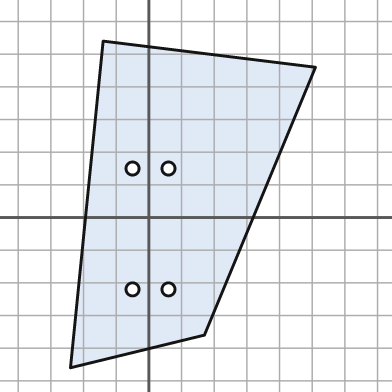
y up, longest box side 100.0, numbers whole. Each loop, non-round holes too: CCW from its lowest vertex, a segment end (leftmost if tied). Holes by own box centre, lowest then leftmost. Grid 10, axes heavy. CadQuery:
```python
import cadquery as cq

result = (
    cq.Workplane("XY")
    .moveTo(-24.0, -46.0)
    .lineTo(17.0, -36.0)
    .lineTo(51.0, 46.0)
    .lineTo(-14.0, 54.0)
    .close()
    .moveTo(-5.0, -22.0)
    .circle(2.0)
    .moveTo(6.0, -22.0)
    .circle(2.0)
    .moveTo(-5.0, 15.0)
    .circle(2.0)
    .moveTo(6.0, 15.0)
    .circle(2.0)
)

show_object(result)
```